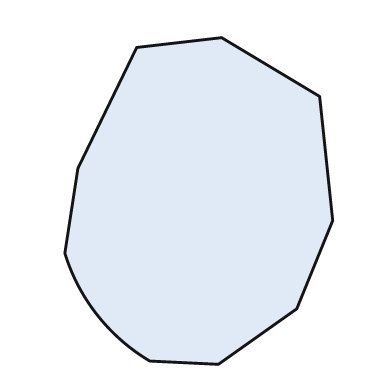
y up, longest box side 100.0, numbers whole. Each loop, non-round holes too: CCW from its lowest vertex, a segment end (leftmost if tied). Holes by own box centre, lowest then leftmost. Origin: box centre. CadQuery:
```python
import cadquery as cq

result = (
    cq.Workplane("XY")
    .moveTo(6.0, -50.0)
    .lineTo(30.0, -33.0)
    .lineTo(41.0, -6.0)
    .lineTo(37.0, 32.0)
    .lineTo(7.0, 50.0)
    .lineTo(-19.0, 47.0)
    .lineTo(-37.0, 10.0)
    .lineTo(-41.0, -16.0)
    .threePointArc((-31.0, -35.0), (-15.0, -49.0))
    .close()
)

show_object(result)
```